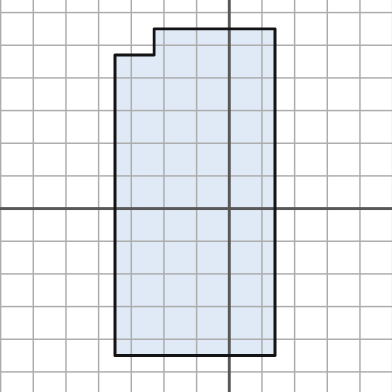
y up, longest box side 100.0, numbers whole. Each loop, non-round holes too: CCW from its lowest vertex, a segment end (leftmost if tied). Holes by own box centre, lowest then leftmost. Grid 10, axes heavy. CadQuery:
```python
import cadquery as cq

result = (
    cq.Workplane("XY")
    .moveTo(-35.0, -45.0)
    .lineTo(14.0, -45.0)
    .lineTo(14.0, 55.0)
    .lineTo(-23.0, 55.0)
    .lineTo(-23.0, 47.0)
    .lineTo(-35.0, 47.0)
    .close()
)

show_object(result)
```